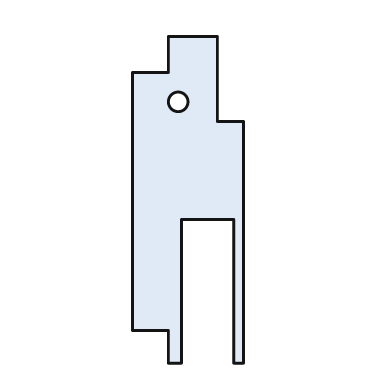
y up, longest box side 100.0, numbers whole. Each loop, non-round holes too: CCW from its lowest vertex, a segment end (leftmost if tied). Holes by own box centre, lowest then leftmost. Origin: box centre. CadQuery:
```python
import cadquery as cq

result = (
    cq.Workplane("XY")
    .moveTo(-6.0, -50.0)
    .lineTo(-2.0, -50.0)
    .lineTo(-2.0, -6.0)
    .lineTo(14.0, -6.0)
    .lineTo(14.0, -50.0)
    .lineTo(17.0, -50.0)
    .lineTo(17.0, 24.0)
    .lineTo(9.0, 24.0)
    .lineTo(9.0, 50.0)
    .lineTo(-6.0, 50.0)
    .lineTo(-6.0, 39.0)
    .lineTo(-17.0, 39.0)
    .lineTo(-17.0, -40.0)
    .lineTo(-6.0, -40.0)
    .close()
    .moveTo(-3.0, 30.0)
    .circle(3.0)
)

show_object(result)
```